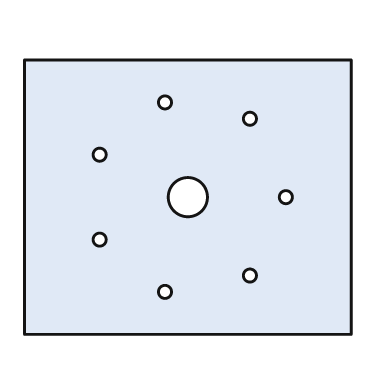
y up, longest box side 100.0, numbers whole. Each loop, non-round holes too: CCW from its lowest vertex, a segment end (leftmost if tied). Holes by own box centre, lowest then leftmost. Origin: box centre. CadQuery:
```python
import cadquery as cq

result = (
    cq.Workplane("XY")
    .moveTo(-50.0, -42.0)
    .lineTo(50.0, -42.0)
    .lineTo(50.0, 42.0)
    .lineTo(-50.0, 42.0)
    .close()
    .moveTo(-7.0, -29.0)
    .circle(2.0)
    .moveTo(19.0, -24.0)
    .circle(2.0)
    .moveTo(-27.0, -13.0)
    .circle(2.0)
    .moveTo(0.0, 0.0)
    .circle(6.0)
    .moveTo(30.0, 0.0)
    .circle(2.0)
    .moveTo(-27.0, 13.0)
    .circle(2.0)
    .moveTo(19.0, 24.0)
    .circle(2.0)
    .moveTo(-7.0, 29.0)
    .circle(2.0)
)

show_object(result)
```